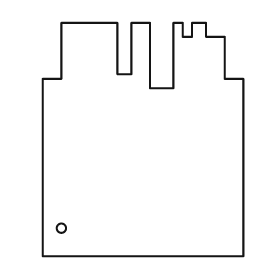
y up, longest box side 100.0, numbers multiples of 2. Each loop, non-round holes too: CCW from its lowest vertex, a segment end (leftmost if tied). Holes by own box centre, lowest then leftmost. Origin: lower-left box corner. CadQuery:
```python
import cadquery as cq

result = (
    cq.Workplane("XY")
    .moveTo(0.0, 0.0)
    .lineTo(86.0, 0.0)
    .lineTo(86.0, 76.0)
    .lineTo(78.0, 76.0)
    .lineTo(78.0, 94.0)
    .lineTo(70.0, 94.0)
    .lineTo(70.0, 100.0)
    .lineTo(64.0, 100.0)
    .lineTo(64.0, 94.0)
    .lineTo(60.0, 94.0)
    .lineTo(60.0, 100.0)
    .lineTo(56.0, 100.0)
    .lineTo(56.0, 72.0)
    .lineTo(46.0, 72.0)
    .lineTo(46.0, 100.0)
    .lineTo(38.0, 100.0)
    .lineTo(38.0, 78.0)
    .lineTo(32.0, 78.0)
    .lineTo(32.0, 100.0)
    .lineTo(8.0, 100.0)
    .lineTo(8.0, 76.0)
    .lineTo(0.0, 76.0)
    .close()
    .moveTo(8.0, 12.0)
    .circle(2.0)
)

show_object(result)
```